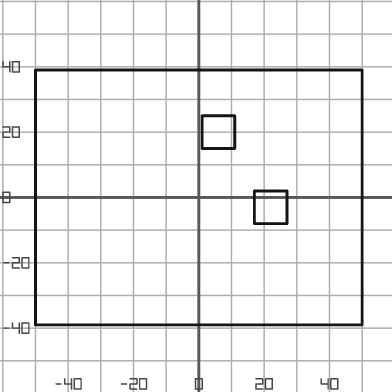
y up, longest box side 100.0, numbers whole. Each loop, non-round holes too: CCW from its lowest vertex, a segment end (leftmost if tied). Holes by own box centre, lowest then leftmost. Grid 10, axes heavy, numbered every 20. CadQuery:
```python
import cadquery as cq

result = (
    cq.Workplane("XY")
    .moveTo(-50.0, -39.0)
    .lineTo(50.0, -39.0)
    .lineTo(50.0, 39.0)
    .lineTo(-50.0, 39.0)
    .close()
    .moveTo(17.0, -8.0)
    .lineTo(27.0, -8.0)
    .lineTo(27.0, 2.0)
    .lineTo(17.0, 2.0)
    .close()
    .moveTo(1.0, 15.0)
    .lineTo(11.0, 15.0)
    .lineTo(11.0, 25.0)
    .lineTo(1.0, 25.0)
    .close()
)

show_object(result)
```